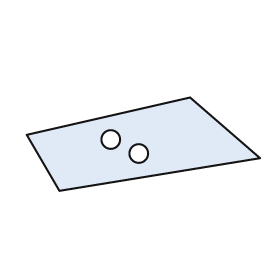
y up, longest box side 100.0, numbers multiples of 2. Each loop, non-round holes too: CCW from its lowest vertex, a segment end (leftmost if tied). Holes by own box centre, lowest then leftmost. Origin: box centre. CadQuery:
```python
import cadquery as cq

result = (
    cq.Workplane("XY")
    .moveTo(-36.0, -20.0)
    .lineTo(50.0, -6.0)
    .lineTo(20.0, 20.0)
    .lineTo(-50.0, 4.0)
    .close()
    .moveTo(-2.0, -4.0)
    .circle(4.0)
    .moveTo(-14.0, 2.0)
    .circle(4.0)
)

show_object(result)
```